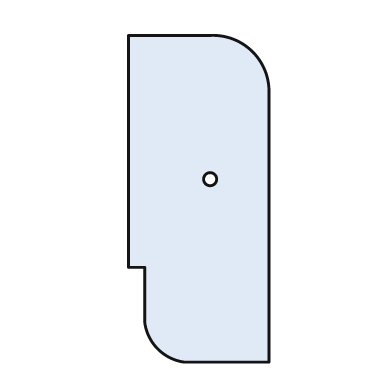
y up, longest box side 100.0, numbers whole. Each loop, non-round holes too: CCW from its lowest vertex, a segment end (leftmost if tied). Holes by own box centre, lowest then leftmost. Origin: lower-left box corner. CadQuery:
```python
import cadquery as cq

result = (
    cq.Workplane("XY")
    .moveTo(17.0, 0.0)
    .lineTo(43.0, 0.0)
    .lineTo(43.0, 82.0)
    .threePointArc((38.0, 95.0), (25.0, 100.0))
    .lineTo(0.0, 100.0)
    .lineTo(0.0, 29.0)
    .lineTo(5.0, 29.0)
    .lineTo(5.0, 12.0)
    .threePointArc((9.0, 4.0), (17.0, 0.0))
    .close()
    .moveTo(25.0, 56.0)
    .circle(2.0)
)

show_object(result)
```